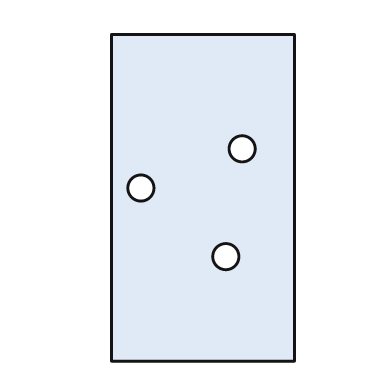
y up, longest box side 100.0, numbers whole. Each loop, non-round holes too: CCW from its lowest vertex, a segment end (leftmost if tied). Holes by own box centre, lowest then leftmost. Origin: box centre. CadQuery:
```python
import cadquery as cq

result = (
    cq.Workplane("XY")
    .moveTo(-28.0, -50.0)
    .lineTo(28.0, -50.0)
    .lineTo(28.0, 50.0)
    .lineTo(-28.0, 50.0)
    .close()
    .moveTo(7.0, -18.0)
    .circle(4.0)
    .moveTo(-19.0, 3.0)
    .circle(4.0)
    .moveTo(12.0, 15.0)
    .circle(4.0)
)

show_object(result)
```